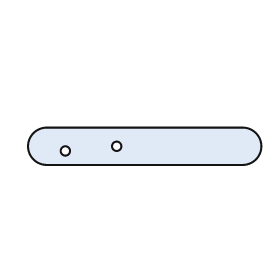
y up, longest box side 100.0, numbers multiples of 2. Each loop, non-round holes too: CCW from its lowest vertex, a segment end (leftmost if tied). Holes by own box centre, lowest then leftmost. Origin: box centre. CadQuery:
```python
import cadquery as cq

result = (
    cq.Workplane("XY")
    .moveTo(-42.0, -8.0)
    .lineTo(42.0, -8.0)
    .threePointArc((50.0, 0.0), (42.0, 8.0))
    .lineTo(-42.0, 8.0)
    .threePointArc((-50.0, 0.0), (-42.0, -8.0))
    .close()
    .moveTo(-34.0, -2.0)
    .circle(2.0)
    .moveTo(-12.0, 0.0)
    .circle(2.0)
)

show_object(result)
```